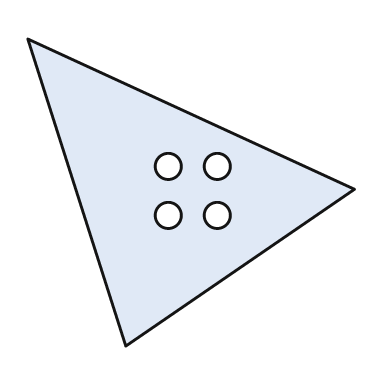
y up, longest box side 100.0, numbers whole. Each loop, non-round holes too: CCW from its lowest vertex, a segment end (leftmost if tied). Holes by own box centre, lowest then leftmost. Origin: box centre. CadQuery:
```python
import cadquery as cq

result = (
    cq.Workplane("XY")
    .moveTo(-20.0, -47.0)
    .lineTo(50.0, 1.0)
    .lineTo(-50.0, 47.0)
    .close()
    .moveTo(-7.0, -7.0)
    .circle(4.0)
    .moveTo(8.0, -7.0)
    .circle(4.0)
    .moveTo(-7.0, 8.0)
    .circle(4.0)
    .moveTo(8.0, 8.0)
    .circle(4.0)
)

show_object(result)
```